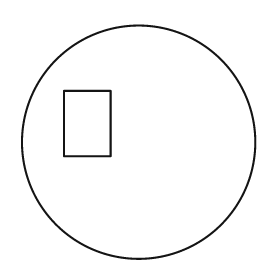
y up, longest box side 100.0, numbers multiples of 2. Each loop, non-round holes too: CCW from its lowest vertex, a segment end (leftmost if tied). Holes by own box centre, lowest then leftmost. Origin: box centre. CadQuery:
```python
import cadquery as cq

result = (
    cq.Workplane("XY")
    .moveTo(0.0, 0.0)
    .circle(50.0)
    .moveTo(-32.0, -6.0)
    .lineTo(-12.0, -6.0)
    .lineTo(-12.0, 22.0)
    .lineTo(-32.0, 22.0)
    .close()
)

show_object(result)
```